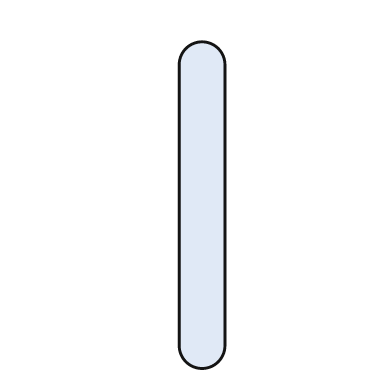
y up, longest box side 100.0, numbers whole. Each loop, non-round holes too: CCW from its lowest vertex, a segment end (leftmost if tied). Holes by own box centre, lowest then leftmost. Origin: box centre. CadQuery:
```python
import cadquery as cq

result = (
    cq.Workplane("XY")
    .moveTo(-7.0, -43.0)
    .threePointArc((0.0, -50.0), (7.0, -43.0))
    .lineTo(7.0, 43.0)
    .threePointArc((0.0, 50.0), (-7.0, 43.0))
    .close()
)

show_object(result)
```